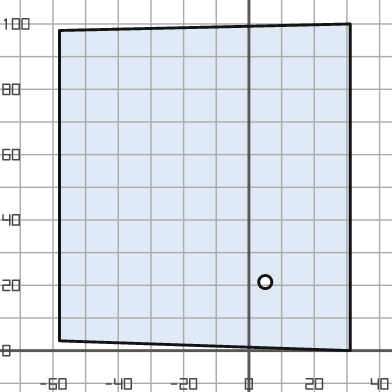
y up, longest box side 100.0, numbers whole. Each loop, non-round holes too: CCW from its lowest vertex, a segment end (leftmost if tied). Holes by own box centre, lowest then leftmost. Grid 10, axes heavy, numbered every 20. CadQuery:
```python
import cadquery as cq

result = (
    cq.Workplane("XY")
    .moveTo(31.0, 0.0)
    .lineTo(31.0, 100.0)
    .lineTo(-58.0, 98.0)
    .lineTo(-58.0, 3.0)
    .close()
    .moveTo(5.0, 21.0)
    .circle(2.0)
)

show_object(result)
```